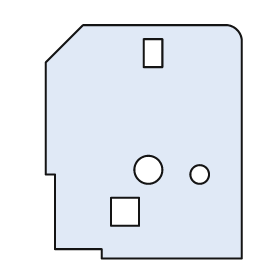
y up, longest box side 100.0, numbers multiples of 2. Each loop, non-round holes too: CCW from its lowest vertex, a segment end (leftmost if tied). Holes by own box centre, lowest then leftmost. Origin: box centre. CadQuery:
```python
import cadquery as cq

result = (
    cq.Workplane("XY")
    .moveTo(-18.0, -50.0)
    .lineTo(42.0, -50.0)
    .lineTo(42.0, 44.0)
    .threePointArc((40.0, 48.0), (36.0, 50.0))
    .lineTo(-26.0, 50.0)
    .lineTo(-42.0, 34.0)
    .lineTo(-42.0, -14.0)
    .lineTo(-38.0, -14.0)
    .lineTo(-38.0, -46.0)
    .lineTo(-18.0, -46.0)
    .close()
    .moveTo(-14.0, -36.0)
    .lineTo(-2.0, -36.0)
    .lineTo(-2.0, -24.0)
    .lineTo(-14.0, -24.0)
    .close()
    .moveTo(24.0, -14.0)
    .circle(4.0)
    .moveTo(2.0, -12.0)
    .circle(6.0)
    .moveTo(0.0, 32.0)
    .lineTo(8.0, 32.0)
    .lineTo(8.0, 44.0)
    .lineTo(0.0, 44.0)
    .close()
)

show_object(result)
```